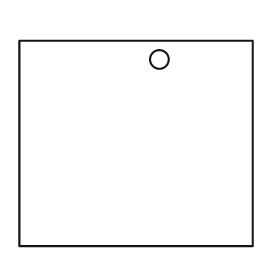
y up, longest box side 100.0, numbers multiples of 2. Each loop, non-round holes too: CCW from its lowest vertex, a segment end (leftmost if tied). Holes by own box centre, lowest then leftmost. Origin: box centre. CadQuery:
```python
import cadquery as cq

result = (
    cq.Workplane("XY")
    .moveTo(-50.0, -44.0)
    .lineTo(50.0, -44.0)
    .lineTo(50.0, 44.0)
    .lineTo(-50.0, 44.0)
    .close()
    .moveTo(10.0, 36.0)
    .circle(4.0)
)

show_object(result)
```